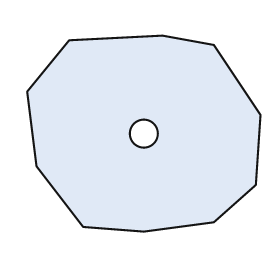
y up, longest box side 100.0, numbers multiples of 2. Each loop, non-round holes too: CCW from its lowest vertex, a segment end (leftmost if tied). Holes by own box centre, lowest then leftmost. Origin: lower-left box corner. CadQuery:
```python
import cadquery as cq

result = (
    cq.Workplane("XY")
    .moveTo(50.0, 0.0)
    .lineTo(80.0, 4.0)
    .lineTo(98.0, 20.0)
    .lineTo(100.0, 50.0)
    .lineTo(80.0, 80.0)
    .lineTo(58.0, 84.0)
    .lineTo(18.0, 82.0)
    .lineTo(0.0, 60.0)
    .lineTo(4.0, 28.0)
    .lineTo(24.0, 2.0)
    .close()
    .moveTo(50.0, 42.0)
    .circle(6.0)
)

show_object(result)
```